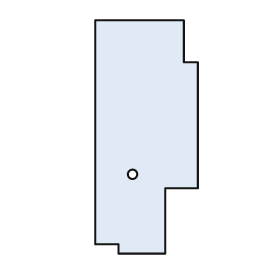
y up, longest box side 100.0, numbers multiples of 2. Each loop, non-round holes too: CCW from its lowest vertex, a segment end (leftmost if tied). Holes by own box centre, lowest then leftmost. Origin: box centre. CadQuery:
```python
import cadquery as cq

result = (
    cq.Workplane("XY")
    .moveTo(-12.0, -50.0)
    .lineTo(8.0, -50.0)
    .lineTo(8.0, -22.0)
    .lineTo(22.0, -22.0)
    .lineTo(22.0, 32.0)
    .lineTo(16.0, 32.0)
    .lineTo(16.0, 50.0)
    .lineTo(-22.0, 50.0)
    .lineTo(-22.0, -46.0)
    .lineTo(-12.0, -46.0)
    .close()
    .moveTo(-6.0, -16.0)
    .circle(2.0)
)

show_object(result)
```